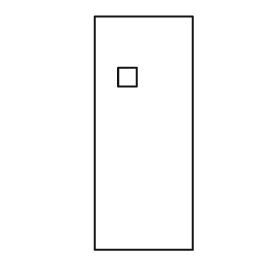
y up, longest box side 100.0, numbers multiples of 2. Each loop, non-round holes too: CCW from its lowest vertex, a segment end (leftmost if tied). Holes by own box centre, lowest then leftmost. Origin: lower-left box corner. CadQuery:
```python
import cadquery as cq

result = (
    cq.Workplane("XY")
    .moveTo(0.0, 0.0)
    .lineTo(42.0, 0.0)
    .lineTo(42.0, 100.0)
    .lineTo(0.0, 100.0)
    .close()
    .moveTo(10.0, 70.0)
    .lineTo(18.0, 70.0)
    .lineTo(18.0, 78.0)
    .lineTo(10.0, 78.0)
    .close()
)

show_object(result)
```